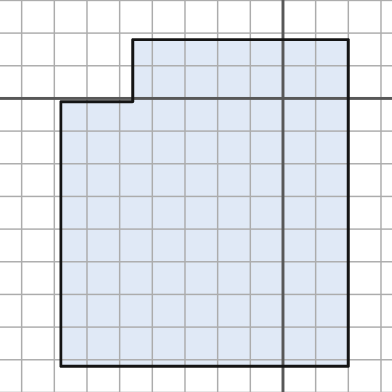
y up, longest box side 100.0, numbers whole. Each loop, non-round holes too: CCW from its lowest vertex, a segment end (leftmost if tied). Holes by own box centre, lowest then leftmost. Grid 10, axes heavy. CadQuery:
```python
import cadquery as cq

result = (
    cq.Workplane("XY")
    .moveTo(-68.0, -82.0)
    .lineTo(20.0, -82.0)
    .lineTo(20.0, 18.0)
    .lineTo(-46.0, 18.0)
    .lineTo(-46.0, -1.0)
    .lineTo(-68.0, -1.0)
    .close()
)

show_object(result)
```